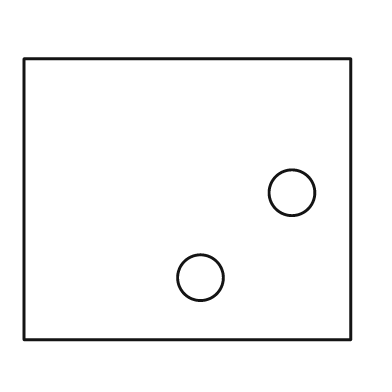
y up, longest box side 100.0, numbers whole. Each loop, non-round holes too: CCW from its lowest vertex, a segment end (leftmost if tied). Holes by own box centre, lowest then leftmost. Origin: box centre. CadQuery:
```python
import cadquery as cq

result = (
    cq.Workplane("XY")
    .moveTo(-50.0, -43.0)
    .lineTo(50.0, -43.0)
    .lineTo(50.0, 43.0)
    .lineTo(-50.0, 43.0)
    .close()
    .moveTo(4.0, -24.0)
    .circle(7.0)
    .moveTo(32.0, 2.0)
    .circle(7.0)
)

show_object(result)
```